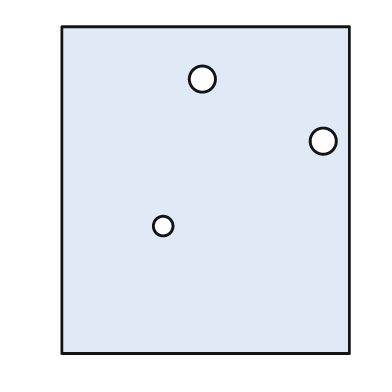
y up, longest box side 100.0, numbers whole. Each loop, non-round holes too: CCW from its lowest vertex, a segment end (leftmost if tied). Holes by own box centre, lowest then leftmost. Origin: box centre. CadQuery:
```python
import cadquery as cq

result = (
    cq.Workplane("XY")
    .moveTo(-44.0, -50.0)
    .lineTo(44.0, -50.0)
    .lineTo(44.0, 50.0)
    .lineTo(-44.0, 50.0)
    .close()
    .moveTo(-13.0, -11.0)
    .circle(3.0)
    .moveTo(36.0, 15.0)
    .circle(4.0)
    .moveTo(-1.0, 34.0)
    .circle(4.0)
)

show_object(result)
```